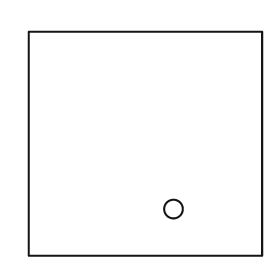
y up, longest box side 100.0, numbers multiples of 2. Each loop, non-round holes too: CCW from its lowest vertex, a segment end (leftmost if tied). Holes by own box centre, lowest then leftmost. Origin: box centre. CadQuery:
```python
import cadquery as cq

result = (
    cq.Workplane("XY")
    .moveTo(-50.0, -48.0)
    .lineTo(50.0, -48.0)
    .lineTo(50.0, 48.0)
    .lineTo(-50.0, 48.0)
    .close()
    .moveTo(12.0, -28.0)
    .circle(4.0)
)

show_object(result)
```